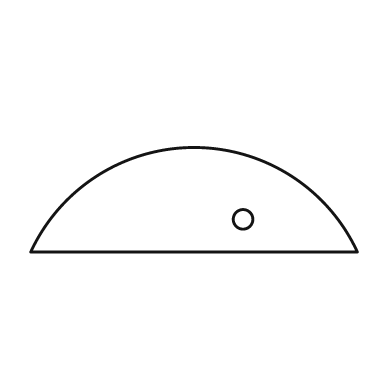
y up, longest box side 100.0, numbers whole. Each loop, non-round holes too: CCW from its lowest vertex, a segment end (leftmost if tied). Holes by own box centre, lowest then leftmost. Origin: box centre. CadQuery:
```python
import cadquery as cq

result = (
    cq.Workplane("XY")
    .moveTo(-50.0, -16.0)
    .lineTo(50.0, -16.0)
    .threePointArc((0.0, 16.0), (-50.0, -16.0))
    .close()
    .moveTo(15.0, -6.0)
    .circle(3.0)
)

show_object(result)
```